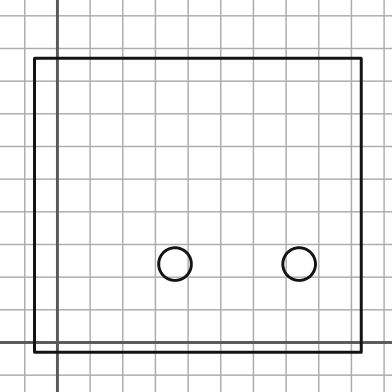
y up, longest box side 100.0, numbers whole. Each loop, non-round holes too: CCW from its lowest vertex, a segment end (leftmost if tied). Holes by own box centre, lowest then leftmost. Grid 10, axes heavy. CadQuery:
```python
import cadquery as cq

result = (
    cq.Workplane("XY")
    .moveTo(-7.0, -3.0)
    .lineTo(93.0, -3.0)
    .lineTo(93.0, 87.0)
    .lineTo(-7.0, 87.0)
    .close()
    .moveTo(36.0, 24.0)
    .circle(5.0)
    .moveTo(74.0, 24.0)
    .circle(5.0)
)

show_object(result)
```